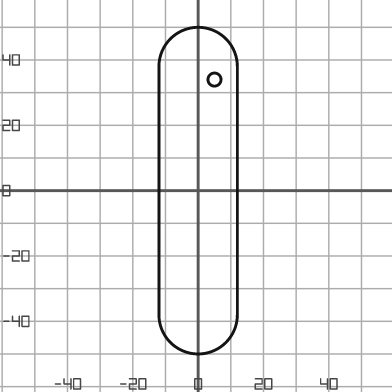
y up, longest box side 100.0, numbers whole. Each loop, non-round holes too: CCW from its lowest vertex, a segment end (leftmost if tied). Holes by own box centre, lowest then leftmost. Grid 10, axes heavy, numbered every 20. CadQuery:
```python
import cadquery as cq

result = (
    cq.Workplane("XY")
    .moveTo(-12.0, -38.0)
    .threePointArc((0.0, -50.0), (12.0, -38.0))
    .lineTo(12.0, 38.0)
    .threePointArc((0.0, 50.0), (-12.0, 38.0))
    .close()
    .moveTo(5.0, 34.0)
    .circle(2.0)
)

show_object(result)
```